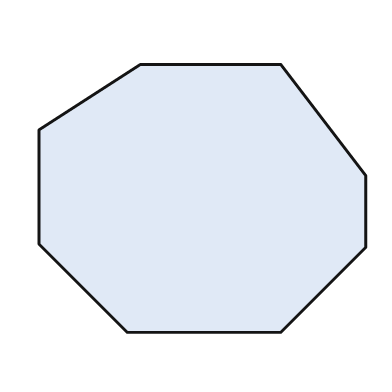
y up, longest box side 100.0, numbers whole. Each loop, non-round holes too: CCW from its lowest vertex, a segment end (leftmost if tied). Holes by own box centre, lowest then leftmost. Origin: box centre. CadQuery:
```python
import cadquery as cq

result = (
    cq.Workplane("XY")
    .moveTo(-23.0, -41.0)
    .lineTo(24.0, -41.0)
    .lineTo(50.0, -15.0)
    .lineTo(50.0, 7.0)
    .lineTo(24.0, 41.0)
    .lineTo(-19.0, 41.0)
    .lineTo(-50.0, 21.0)
    .lineTo(-50.0, -14.0)
    .close()
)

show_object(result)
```